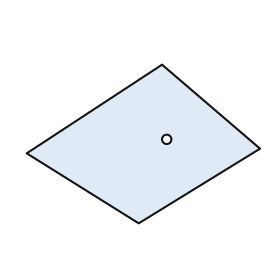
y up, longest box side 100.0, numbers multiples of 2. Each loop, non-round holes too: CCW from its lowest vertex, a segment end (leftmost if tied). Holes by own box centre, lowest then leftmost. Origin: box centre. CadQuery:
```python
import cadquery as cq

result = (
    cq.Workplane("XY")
    .moveTo(-2.0, -34.0)
    .lineTo(50.0, -2.0)
    .lineTo(8.0, 34.0)
    .lineTo(-50.0, -4.0)
    .close()
    .moveTo(10.0, 2.0)
    .circle(2.0)
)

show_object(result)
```